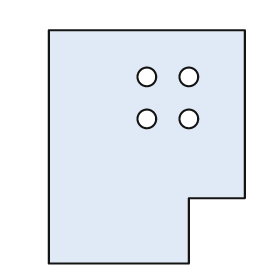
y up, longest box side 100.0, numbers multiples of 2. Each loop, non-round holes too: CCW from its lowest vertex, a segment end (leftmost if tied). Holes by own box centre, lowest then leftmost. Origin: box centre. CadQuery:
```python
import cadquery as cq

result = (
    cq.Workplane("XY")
    .moveTo(-42.0, -50.0)
    .lineTo(18.0, -50.0)
    .lineTo(18.0, -22.0)
    .lineTo(42.0, -22.0)
    .lineTo(42.0, 50.0)
    .lineTo(-42.0, 50.0)
    .close()
    .moveTo(0.0, 12.0)
    .circle(4.0)
    .moveTo(18.0, 12.0)
    .circle(4.0)
    .moveTo(0.0, 30.0)
    .circle(4.0)
    .moveTo(18.0, 30.0)
    .circle(4.0)
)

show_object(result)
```